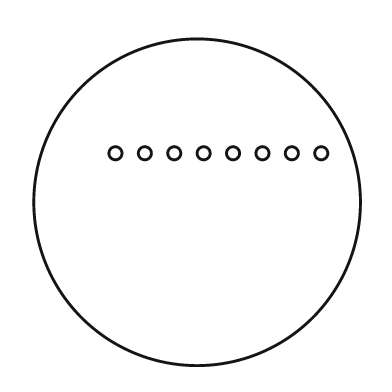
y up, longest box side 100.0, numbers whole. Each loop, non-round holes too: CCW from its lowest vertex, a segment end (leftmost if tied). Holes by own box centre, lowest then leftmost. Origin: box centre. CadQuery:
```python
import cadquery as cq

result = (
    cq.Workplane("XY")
    .moveTo(0.0, 0.0)
    .circle(50.0)
    .moveTo(-25.0, 15.0)
    .circle(2.0)
    .moveTo(-16.0, 15.0)
    .circle(2.0)
    .moveTo(-7.0, 15.0)
    .circle(2.0)
    .moveTo(2.0, 15.0)
    .circle(2.0)
    .moveTo(11.0, 15.0)
    .circle(2.0)
    .moveTo(20.0, 15.0)
    .circle(2.0)
    .moveTo(29.0, 15.0)
    .circle(2.0)
    .moveTo(38.0, 15.0)
    .circle(2.0)
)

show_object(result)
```